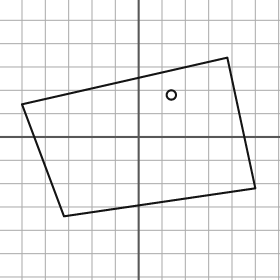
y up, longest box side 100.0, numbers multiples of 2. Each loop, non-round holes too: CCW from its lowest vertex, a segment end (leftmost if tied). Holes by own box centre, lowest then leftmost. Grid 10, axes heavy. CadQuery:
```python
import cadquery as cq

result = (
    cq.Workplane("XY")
    .moveTo(-32.0, -34.0)
    .lineTo(50.0, -22.0)
    .lineTo(38.0, 34.0)
    .lineTo(-50.0, 14.0)
    .close()
    .moveTo(14.0, 18.0)
    .circle(2.0)
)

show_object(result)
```